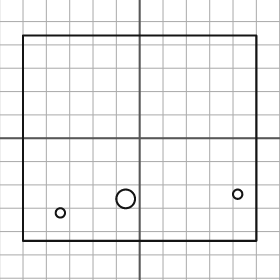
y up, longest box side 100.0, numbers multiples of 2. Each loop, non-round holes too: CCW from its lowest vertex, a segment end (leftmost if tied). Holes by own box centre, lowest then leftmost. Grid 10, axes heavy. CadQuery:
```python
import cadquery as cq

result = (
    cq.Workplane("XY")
    .moveTo(-50.0, -44.0)
    .lineTo(50.0, -44.0)
    .lineTo(50.0, 44.0)
    .lineTo(-50.0, 44.0)
    .close()
    .moveTo(-34.0, -32.0)
    .circle(2.0)
    .moveTo(-6.0, -26.0)
    .circle(4.0)
    .moveTo(42.0, -24.0)
    .circle(2.0)
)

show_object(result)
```